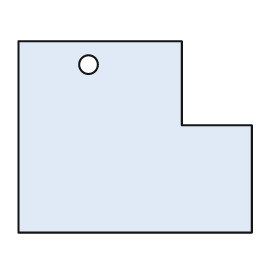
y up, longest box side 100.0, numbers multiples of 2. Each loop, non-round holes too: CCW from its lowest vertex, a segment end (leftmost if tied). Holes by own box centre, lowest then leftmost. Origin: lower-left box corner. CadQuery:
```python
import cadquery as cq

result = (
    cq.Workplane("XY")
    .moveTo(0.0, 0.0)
    .lineTo(100.0, 0.0)
    .lineTo(100.0, 46.0)
    .lineTo(70.0, 46.0)
    .lineTo(70.0, 82.0)
    .lineTo(0.0, 82.0)
    .close()
    .moveTo(30.0, 72.0)
    .circle(4.0)
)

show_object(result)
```